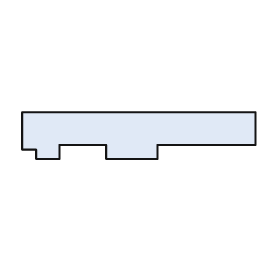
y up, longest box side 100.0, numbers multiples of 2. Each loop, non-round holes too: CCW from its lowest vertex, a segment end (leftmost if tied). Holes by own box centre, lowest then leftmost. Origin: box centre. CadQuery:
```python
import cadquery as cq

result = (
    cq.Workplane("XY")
    .moveTo(-44.0, -10.0)
    .lineTo(-34.0, -10.0)
    .lineTo(-34.0, -4.0)
    .lineTo(-14.0, -4.0)
    .lineTo(-14.0, -10.0)
    .lineTo(8.0, -10.0)
    .lineTo(8.0, -4.0)
    .lineTo(50.0, -4.0)
    .lineTo(50.0, 10.0)
    .lineTo(-50.0, 10.0)
    .lineTo(-50.0, -6.0)
    .lineTo(-44.0, -6.0)
    .close()
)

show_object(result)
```